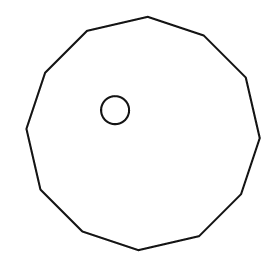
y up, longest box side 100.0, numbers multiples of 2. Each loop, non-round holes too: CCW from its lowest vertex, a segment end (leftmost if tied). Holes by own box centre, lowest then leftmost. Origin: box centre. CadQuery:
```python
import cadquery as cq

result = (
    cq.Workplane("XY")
    .moveTo(-2.0, -50.0)
    .lineTo(24.0, -44.0)
    .lineTo(42.0, -26.0)
    .lineTo(50.0, -2.0)
    .lineTo(44.0, 24.0)
    .lineTo(26.0, 42.0)
    .lineTo(2.0, 50.0)
    .lineTo(-24.0, 44.0)
    .lineTo(-42.0, 26.0)
    .lineTo(-50.0, 2.0)
    .lineTo(-44.0, -24.0)
    .lineTo(-26.0, -42.0)
    .close()
    .moveTo(-12.0, 10.0)
    .circle(6.0)
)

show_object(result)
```